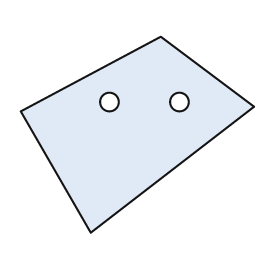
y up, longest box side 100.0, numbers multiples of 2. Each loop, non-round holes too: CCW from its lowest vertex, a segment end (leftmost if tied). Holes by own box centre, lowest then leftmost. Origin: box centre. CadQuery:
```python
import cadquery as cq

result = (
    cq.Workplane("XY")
    .moveTo(-20.0, -42.0)
    .lineTo(50.0, 12.0)
    .lineTo(10.0, 42.0)
    .lineTo(-50.0, 10.0)
    .close()
    .moveTo(-12.0, 14.0)
    .circle(4.0)
    .moveTo(18.0, 14.0)
    .circle(4.0)
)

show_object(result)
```